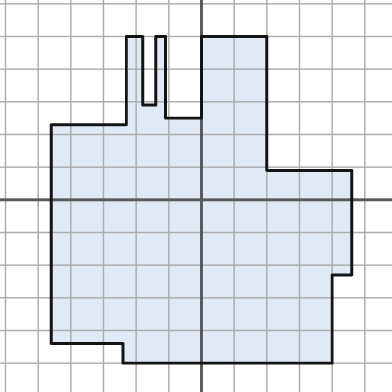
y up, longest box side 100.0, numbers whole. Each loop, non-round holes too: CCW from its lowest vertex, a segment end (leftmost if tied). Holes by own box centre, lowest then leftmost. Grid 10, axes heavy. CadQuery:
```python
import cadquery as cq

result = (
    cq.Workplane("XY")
    .moveTo(-24.0, -50.0)
    .lineTo(40.0, -50.0)
    .lineTo(40.0, -23.0)
    .lineTo(46.0, -23.0)
    .lineTo(46.0, 9.0)
    .lineTo(20.0, 9.0)
    .lineTo(20.0, 50.0)
    .lineTo(0.0, 50.0)
    .lineTo(0.0, 25.0)
    .lineTo(-11.0, 25.0)
    .lineTo(-11.0, 50.0)
    .lineTo(-14.0, 50.0)
    .lineTo(-14.0, 29.0)
    .lineTo(-18.0, 29.0)
    .lineTo(-18.0, 50.0)
    .lineTo(-23.0, 50.0)
    .lineTo(-23.0, 23.0)
    .lineTo(-46.0, 23.0)
    .lineTo(-46.0, -44.0)
    .lineTo(-24.0, -44.0)
    .close()
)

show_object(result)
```